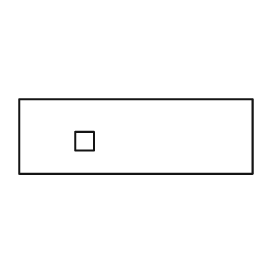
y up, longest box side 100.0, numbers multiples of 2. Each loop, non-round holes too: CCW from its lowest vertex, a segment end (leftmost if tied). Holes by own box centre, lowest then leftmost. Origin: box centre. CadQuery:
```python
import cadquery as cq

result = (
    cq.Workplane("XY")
    .moveTo(-50.0, -16.0)
    .lineTo(50.0, -16.0)
    .lineTo(50.0, 16.0)
    .lineTo(-50.0, 16.0)
    .close()
    .moveTo(-26.0, -6.0)
    .lineTo(-18.0, -6.0)
    .lineTo(-18.0, 2.0)
    .lineTo(-26.0, 2.0)
    .close()
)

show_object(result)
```